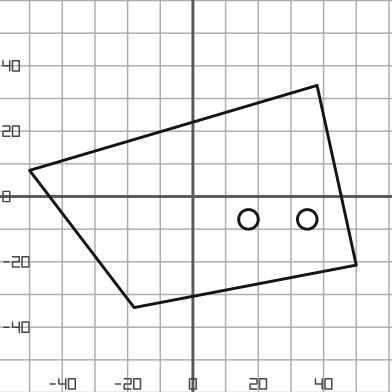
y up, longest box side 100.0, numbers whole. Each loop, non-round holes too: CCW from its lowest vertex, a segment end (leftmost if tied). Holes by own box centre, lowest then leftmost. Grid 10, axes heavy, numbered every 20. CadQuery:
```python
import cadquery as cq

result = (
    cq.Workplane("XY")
    .moveTo(-18.0, -34.0)
    .lineTo(50.0, -21.0)
    .lineTo(38.0, 34.0)
    .lineTo(-50.0, 8.0)
    .close()
    .moveTo(17.0, -7.0)
    .circle(3.0)
    .moveTo(35.0, -7.0)
    .circle(3.0)
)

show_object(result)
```